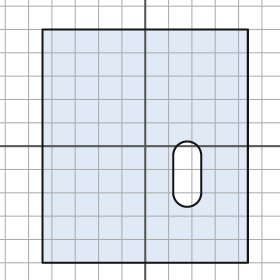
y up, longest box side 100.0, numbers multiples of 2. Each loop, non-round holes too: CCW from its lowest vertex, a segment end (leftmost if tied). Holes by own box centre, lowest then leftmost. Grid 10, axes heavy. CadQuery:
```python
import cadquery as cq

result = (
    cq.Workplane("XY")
    .moveTo(-44.0, -50.0)
    .lineTo(44.0, -50.0)
    .lineTo(44.0, 50.0)
    .lineTo(-44.0, 50.0)
    .close()
    .moveTo(12.0, -20.0)
    .threePointArc((18.0, -26.0), (24.0, -20.0))
    .lineTo(24.0, -4.0)
    .threePointArc((18.0, 2.0), (12.0, -4.0))
    .close()
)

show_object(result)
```